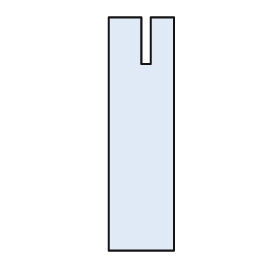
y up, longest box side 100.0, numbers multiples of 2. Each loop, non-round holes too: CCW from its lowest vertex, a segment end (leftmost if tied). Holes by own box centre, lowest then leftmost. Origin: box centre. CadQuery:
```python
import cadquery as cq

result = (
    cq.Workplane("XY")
    .moveTo(-14.0, -50.0)
    .lineTo(14.0, -50.0)
    .lineTo(14.0, 50.0)
    .lineTo(4.0, 50.0)
    .lineTo(4.0, 30.0)
    .lineTo(0.0, 30.0)
    .lineTo(0.0, 50.0)
    .lineTo(-14.0, 50.0)
    .close()
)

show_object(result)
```